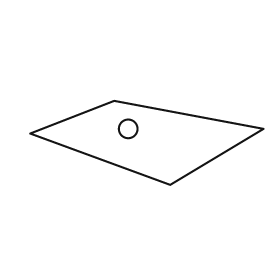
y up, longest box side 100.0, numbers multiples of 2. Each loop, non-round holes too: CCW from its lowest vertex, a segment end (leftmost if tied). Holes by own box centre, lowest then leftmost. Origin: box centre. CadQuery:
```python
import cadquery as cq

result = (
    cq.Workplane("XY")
    .moveTo(10.0, -18.0)
    .lineTo(50.0, 6.0)
    .lineTo(-14.0, 18.0)
    .lineTo(-50.0, 4.0)
    .close()
    .moveTo(-8.0, 6.0)
    .circle(4.0)
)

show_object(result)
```